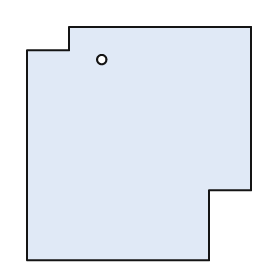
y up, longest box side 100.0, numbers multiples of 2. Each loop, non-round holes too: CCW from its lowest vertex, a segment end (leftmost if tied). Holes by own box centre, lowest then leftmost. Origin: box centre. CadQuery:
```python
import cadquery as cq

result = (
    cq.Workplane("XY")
    .moveTo(-48.0, -50.0)
    .lineTo(30.0, -50.0)
    .lineTo(30.0, -20.0)
    .lineTo(48.0, -20.0)
    .lineTo(48.0, 50.0)
    .lineTo(-30.0, 50.0)
    .lineTo(-30.0, 40.0)
    .lineTo(-48.0, 40.0)
    .close()
    .moveTo(-16.0, 36.0)
    .circle(2.0)
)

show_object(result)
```